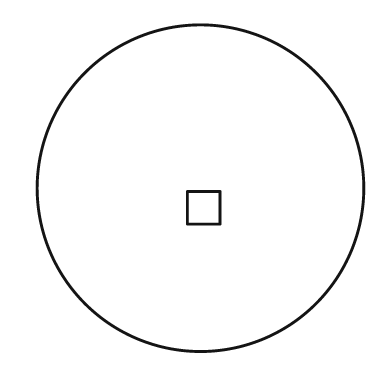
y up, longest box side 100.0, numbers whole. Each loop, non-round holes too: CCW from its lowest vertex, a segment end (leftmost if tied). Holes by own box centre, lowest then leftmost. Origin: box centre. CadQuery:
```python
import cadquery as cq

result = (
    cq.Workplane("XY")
    .moveTo(0.0, 0.0)
    .circle(50.0)
    .moveTo(-4.0, -11.0)
    .lineTo(6.0, -11.0)
    .lineTo(6.0, -1.0)
    .lineTo(-4.0, -1.0)
    .close()
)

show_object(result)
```